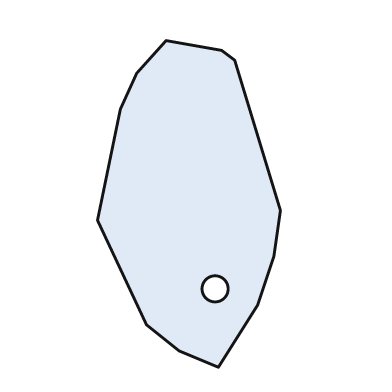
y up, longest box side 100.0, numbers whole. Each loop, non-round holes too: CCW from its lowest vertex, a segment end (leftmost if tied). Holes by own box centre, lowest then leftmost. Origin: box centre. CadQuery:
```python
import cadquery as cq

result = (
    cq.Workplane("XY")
    .moveTo(9.0, -50.0)
    .lineTo(21.0, -31.0)
    .lineTo(26.0, -16.0)
    .lineTo(28.0, -2.0)
    .lineTo(14.0, 44.0)
    .lineTo(10.0, 47.0)
    .lineTo(-7.0, 50.0)
    .lineTo(-16.0, 40.0)
    .lineTo(-21.0, 29.0)
    .lineTo(-28.0, -5.0)
    .lineTo(-13.0, -37.0)
    .lineTo(-3.0, -45.0)
    .close()
    .moveTo(8.0, -26.0)
    .circle(4.0)
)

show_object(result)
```